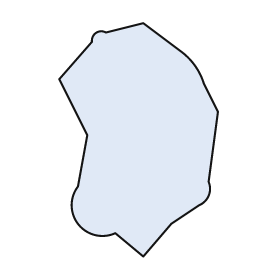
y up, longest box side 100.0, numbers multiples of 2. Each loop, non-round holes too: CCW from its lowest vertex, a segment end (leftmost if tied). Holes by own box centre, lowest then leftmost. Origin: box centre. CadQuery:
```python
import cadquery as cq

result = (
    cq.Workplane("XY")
    .moveTo(2.0, -50.0)
    .lineTo(14.0, -36.0)
    .lineTo(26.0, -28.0)
    .threePointArc((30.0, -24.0), (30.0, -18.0))
    .lineTo(34.0, 12.0)
    .lineTo(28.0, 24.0)
    .threePointArc((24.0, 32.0), (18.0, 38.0))
    .lineTo(2.0, 50.0)
    .lineTo(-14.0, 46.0)
    .threePointArc((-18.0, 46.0), (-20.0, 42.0))
    .lineTo(-34.0, 26.0)
    .lineTo(-22.0, 2.0)
    .lineTo(-26.0, -20.0)
    .threePointArc((-26.0, -36.0), (-10.0, -40.0))
    .close()
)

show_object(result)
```